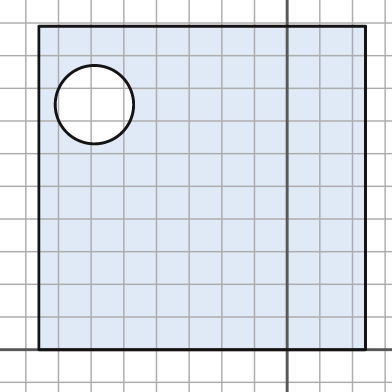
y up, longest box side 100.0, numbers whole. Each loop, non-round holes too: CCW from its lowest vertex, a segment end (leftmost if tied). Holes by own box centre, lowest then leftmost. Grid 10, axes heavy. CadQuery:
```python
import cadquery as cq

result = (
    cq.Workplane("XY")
    .moveTo(-76.0, 0.0)
    .lineTo(24.0, 0.0)
    .lineTo(24.0, 99.0)
    .lineTo(-76.0, 99.0)
    .close()
    .moveTo(-59.0, 75.0)
    .circle(12.0)
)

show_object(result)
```